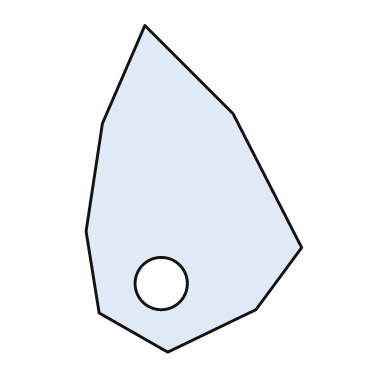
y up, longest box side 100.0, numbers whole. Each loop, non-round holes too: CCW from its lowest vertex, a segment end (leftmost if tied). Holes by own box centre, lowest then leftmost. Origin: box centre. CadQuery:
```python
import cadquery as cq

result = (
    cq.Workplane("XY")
    .moveTo(-8.0, -50.0)
    .lineTo(19.0, -37.0)
    .lineTo(33.0, -18.0)
    .lineTo(12.0, 23.0)
    .lineTo(-15.0, 50.0)
    .lineTo(-28.0, 20.0)
    .lineTo(-33.0, -13.0)
    .lineTo(-29.0, -38.0)
    .close()
    .moveTo(-10.0, -29.0)
    .circle(8.0)
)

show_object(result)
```